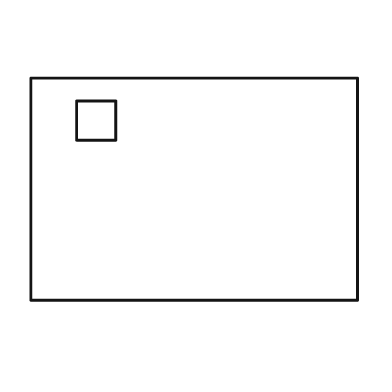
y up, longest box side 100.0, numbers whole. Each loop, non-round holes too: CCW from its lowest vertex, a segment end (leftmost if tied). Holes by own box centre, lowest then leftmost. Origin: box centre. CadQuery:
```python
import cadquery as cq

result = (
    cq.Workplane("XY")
    .moveTo(-50.0, -34.0)
    .lineTo(50.0, -34.0)
    .lineTo(50.0, 34.0)
    .lineTo(-50.0, 34.0)
    .close()
    .moveTo(-36.0, 15.0)
    .lineTo(-24.0, 15.0)
    .lineTo(-24.0, 27.0)
    .lineTo(-36.0, 27.0)
    .close()
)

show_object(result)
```